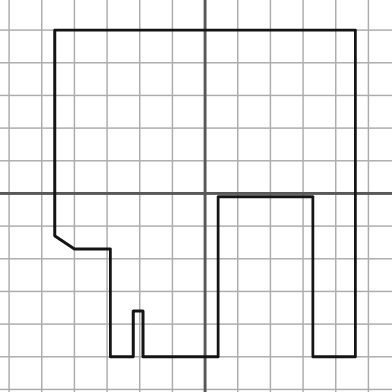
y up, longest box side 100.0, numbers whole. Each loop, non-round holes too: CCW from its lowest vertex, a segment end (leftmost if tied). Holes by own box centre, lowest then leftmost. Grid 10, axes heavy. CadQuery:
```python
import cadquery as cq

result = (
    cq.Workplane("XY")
    .moveTo(-29.0, -50.0)
    .lineTo(-22.0, -50.0)
    .lineTo(-22.0, -36.0)
    .lineTo(-19.0, -36.0)
    .lineTo(-19.0, -50.0)
    .lineTo(4.0, -50.0)
    .lineTo(4.0, -1.0)
    .lineTo(33.0, -1.0)
    .lineTo(33.0, -50.0)
    .lineTo(46.0, -50.0)
    .lineTo(46.0, 50.0)
    .lineTo(-46.0, 50.0)
    .lineTo(-46.0, -13.0)
    .lineTo(-40.0, -17.0)
    .lineTo(-29.0, -17.0)
    .close()
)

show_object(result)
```